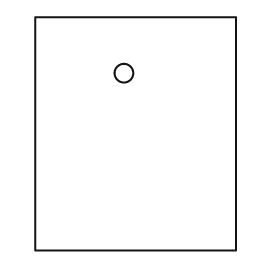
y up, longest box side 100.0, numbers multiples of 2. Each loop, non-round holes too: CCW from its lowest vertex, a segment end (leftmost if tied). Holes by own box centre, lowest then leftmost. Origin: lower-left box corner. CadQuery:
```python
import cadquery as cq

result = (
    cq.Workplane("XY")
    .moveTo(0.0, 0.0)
    .lineTo(86.0, 0.0)
    .lineTo(86.0, 100.0)
    .lineTo(0.0, 100.0)
    .close()
    .moveTo(38.0, 76.0)
    .circle(4.0)
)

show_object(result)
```